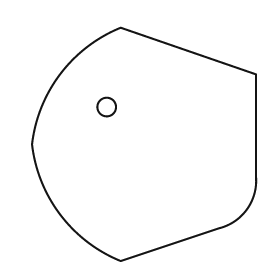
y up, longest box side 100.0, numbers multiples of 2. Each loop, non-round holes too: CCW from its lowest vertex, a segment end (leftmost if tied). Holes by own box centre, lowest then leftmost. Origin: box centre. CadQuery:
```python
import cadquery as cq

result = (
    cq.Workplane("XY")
    .moveTo(-10.0, -50.0)
    .lineTo(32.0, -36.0)
    .threePointArc((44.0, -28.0), (48.0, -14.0))
    .lineTo(48.0, 30.0)
    .lineTo(-10.0, 50.0)
    .threePointArc((-36.0, 30.0), (-48.0, 0.0))
    .threePointArc((-36.0, -30.0), (-10.0, -50.0))
    .close()
    .moveTo(-16.0, 16.0)
    .circle(4.0)
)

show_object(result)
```